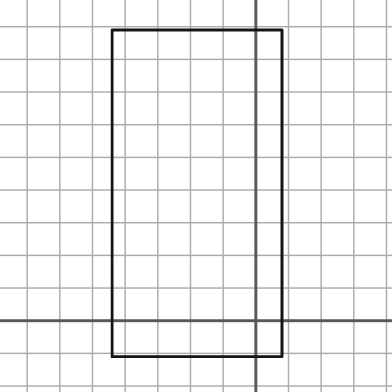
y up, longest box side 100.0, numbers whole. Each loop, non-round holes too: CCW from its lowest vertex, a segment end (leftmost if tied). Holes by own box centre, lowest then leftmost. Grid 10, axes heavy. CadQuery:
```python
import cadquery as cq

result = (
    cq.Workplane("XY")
    .moveTo(-44.0, -11.0)
    .lineTo(8.0, -11.0)
    .lineTo(8.0, 89.0)
    .lineTo(-44.0, 89.0)
    .close()
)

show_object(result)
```